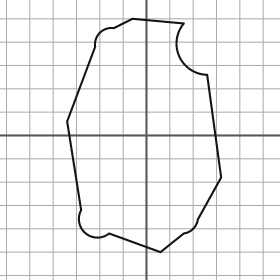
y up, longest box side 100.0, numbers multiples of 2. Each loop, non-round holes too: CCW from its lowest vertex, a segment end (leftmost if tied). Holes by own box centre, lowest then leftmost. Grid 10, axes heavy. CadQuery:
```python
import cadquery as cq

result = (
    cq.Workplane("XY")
    .moveTo(6.0, -50.0)
    .lineTo(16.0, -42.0)
    .threePointArc((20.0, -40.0), (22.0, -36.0))
    .lineTo(32.0, -18.0)
    .lineTo(26.0, 26.0)
    .threePointArc((14.0, 34.0), (16.0, 48.0))
    .lineTo(-6.0, 50.0)
    .lineTo(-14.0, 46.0)
    .threePointArc((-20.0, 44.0), (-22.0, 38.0))
    .lineTo(-34.0, 6.0)
    .lineTo(-28.0, -32.0)
    .threePointArc((-26.0, -42.0), (-16.0, -42.0))
    .close()
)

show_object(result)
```